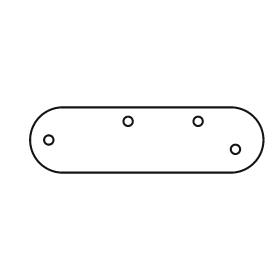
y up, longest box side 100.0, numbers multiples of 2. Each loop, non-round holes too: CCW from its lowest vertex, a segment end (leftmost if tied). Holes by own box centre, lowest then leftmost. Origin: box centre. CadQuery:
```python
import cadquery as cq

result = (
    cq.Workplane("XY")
    .moveTo(-36.0, -14.0)
    .lineTo(36.0, -14.0)
    .threePointArc((50.0, 0.0), (36.0, 14.0))
    .lineTo(-36.0, 14.0)
    .threePointArc((-50.0, 0.0), (-36.0, -14.0))
    .close()
    .moveTo(38.0, -4.0)
    .circle(2.0)
    .moveTo(-42.0, 0.0)
    .circle(2.0)
    .moveTo(-8.0, 8.0)
    .circle(2.0)
    .moveTo(22.0, 8.0)
    .circle(2.0)
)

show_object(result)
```